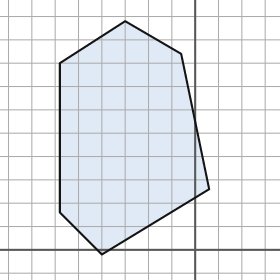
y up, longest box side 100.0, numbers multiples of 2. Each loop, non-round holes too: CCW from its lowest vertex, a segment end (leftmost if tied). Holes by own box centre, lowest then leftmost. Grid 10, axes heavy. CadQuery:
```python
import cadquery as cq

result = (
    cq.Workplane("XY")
    .moveTo(-40.0, -2.0)
    .lineTo(6.0, 26.0)
    .lineTo(-6.0, 84.0)
    .lineTo(-30.0, 98.0)
    .lineTo(-58.0, 80.0)
    .lineTo(-58.0, 16.0)
    .close()
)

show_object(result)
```